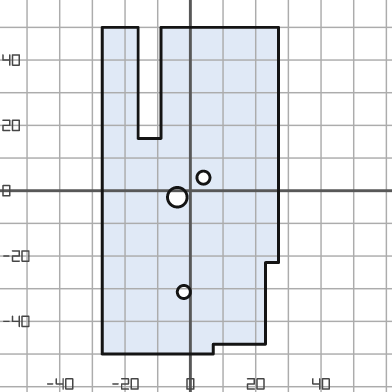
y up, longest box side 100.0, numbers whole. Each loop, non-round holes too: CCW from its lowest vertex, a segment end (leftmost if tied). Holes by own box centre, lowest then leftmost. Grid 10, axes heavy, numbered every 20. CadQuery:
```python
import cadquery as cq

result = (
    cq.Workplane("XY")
    .moveTo(-27.0, -50.0)
    .lineTo(7.0, -50.0)
    .lineTo(7.0, -47.0)
    .lineTo(23.0, -47.0)
    .lineTo(23.0, -22.0)
    .lineTo(27.0, -22.0)
    .lineTo(27.0, 50.0)
    .lineTo(-9.0, 50.0)
    .lineTo(-9.0, 16.0)
    .lineTo(-16.0, 16.0)
    .lineTo(-16.0, 50.0)
    .lineTo(-27.0, 50.0)
    .close()
    .moveTo(-2.0, -31.0)
    .circle(2.0)
    .moveTo(-4.0, -2.0)
    .circle(3.0)
    .moveTo(4.0, 4.0)
    .circle(2.0)
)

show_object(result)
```